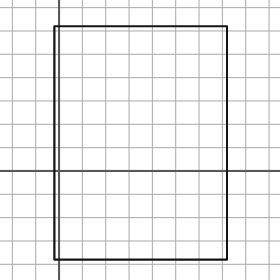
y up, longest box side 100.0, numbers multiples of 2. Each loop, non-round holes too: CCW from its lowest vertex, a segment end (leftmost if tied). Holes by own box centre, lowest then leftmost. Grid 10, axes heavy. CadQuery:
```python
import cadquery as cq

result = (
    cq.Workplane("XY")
    .moveTo(-2.0, -38.0)
    .lineTo(72.0, -38.0)
    .lineTo(72.0, 62.0)
    .lineTo(-2.0, 62.0)
    .close()
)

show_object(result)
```